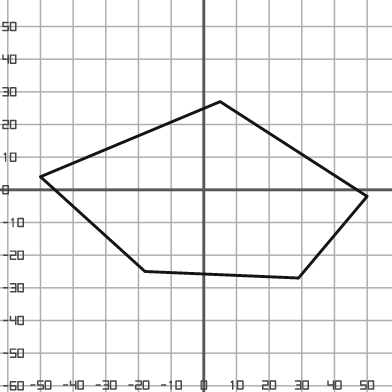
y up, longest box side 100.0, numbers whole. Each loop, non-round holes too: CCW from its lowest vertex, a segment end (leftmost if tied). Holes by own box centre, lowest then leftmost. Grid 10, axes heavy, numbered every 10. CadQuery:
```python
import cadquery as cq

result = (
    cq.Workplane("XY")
    .moveTo(29.0, -27.0)
    .lineTo(50.0, -2.0)
    .lineTo(5.0, 27.0)
    .lineTo(-50.0, 4.0)
    .lineTo(-18.0, -25.0)
    .close()
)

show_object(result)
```